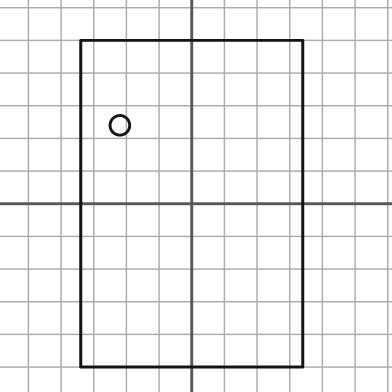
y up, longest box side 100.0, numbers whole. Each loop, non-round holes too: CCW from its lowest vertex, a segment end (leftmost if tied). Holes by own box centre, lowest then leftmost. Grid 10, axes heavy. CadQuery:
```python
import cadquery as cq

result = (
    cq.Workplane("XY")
    .moveTo(-34.0, -50.0)
    .lineTo(34.0, -50.0)
    .lineTo(34.0, 50.0)
    .lineTo(-34.0, 50.0)
    .close()
    .moveTo(-22.0, 24.0)
    .circle(3.0)
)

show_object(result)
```